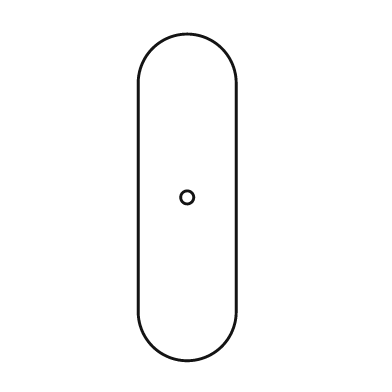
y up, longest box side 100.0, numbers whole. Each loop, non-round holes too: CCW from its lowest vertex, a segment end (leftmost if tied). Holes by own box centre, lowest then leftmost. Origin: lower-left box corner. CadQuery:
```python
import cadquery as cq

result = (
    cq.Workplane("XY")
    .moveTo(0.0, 15.0)
    .threePointArc((15.0, 0.0), (30.0, 15.0))
    .lineTo(30.0, 85.0)
    .threePointArc((15.0, 100.0), (0.0, 85.0))
    .close()
    .moveTo(15.0, 50.0)
    .circle(2.0)
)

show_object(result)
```